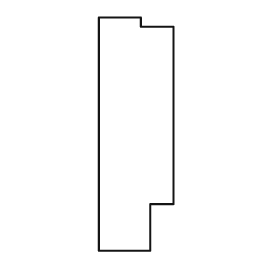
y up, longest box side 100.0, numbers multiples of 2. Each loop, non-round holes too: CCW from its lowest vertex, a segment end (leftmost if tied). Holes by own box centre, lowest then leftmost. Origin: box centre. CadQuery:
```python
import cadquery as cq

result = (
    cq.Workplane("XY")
    .moveTo(-16.0, -50.0)
    .lineTo(6.0, -50.0)
    .lineTo(6.0, -30.0)
    .lineTo(16.0, -30.0)
    .lineTo(16.0, 46.0)
    .lineTo(2.0, 46.0)
    .lineTo(2.0, 50.0)
    .lineTo(-16.0, 50.0)
    .close()
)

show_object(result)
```